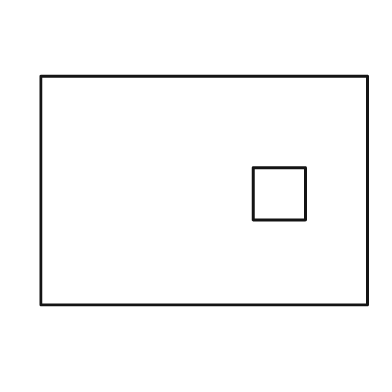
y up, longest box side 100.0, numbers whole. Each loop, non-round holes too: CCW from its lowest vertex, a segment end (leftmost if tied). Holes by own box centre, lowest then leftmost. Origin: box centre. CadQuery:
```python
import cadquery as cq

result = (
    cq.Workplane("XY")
    .moveTo(-50.0, -35.0)
    .lineTo(50.0, -35.0)
    .lineTo(50.0, 35.0)
    .lineTo(-50.0, 35.0)
    .close()
    .moveTo(15.0, -9.0)
    .lineTo(31.0, -9.0)
    .lineTo(31.0, 7.0)
    .lineTo(15.0, 7.0)
    .close()
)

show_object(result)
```